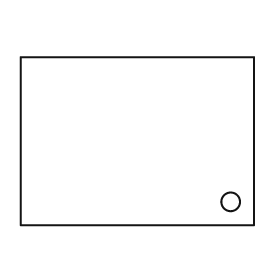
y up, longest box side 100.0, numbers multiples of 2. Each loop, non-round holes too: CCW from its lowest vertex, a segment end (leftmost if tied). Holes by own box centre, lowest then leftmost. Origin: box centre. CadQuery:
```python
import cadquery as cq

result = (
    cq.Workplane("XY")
    .moveTo(-50.0, -36.0)
    .lineTo(50.0, -36.0)
    .lineTo(50.0, 36.0)
    .lineTo(-50.0, 36.0)
    .close()
    .moveTo(40.0, -26.0)
    .circle(4.0)
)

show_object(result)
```